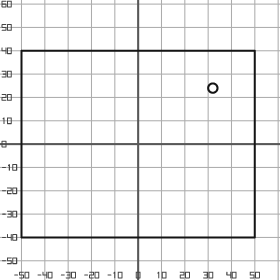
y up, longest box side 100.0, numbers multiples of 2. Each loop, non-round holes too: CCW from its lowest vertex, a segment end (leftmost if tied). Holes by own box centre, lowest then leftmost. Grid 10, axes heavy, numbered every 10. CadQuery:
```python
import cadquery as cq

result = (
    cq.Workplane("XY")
    .moveTo(-50.0, -40.0)
    .lineTo(50.0, -40.0)
    .lineTo(50.0, 40.0)
    .lineTo(-50.0, 40.0)
    .close()
    .moveTo(32.0, 24.0)
    .circle(2.0)
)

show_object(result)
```